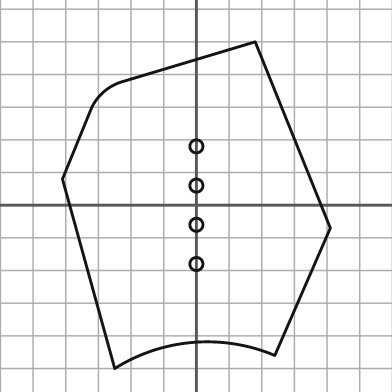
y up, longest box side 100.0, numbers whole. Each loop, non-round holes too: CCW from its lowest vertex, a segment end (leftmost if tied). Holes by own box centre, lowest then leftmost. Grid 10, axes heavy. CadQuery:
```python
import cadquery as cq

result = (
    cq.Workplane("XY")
    .moveTo(-25.0, -50.0)
    .threePointArc((-1.0, -42.0), (24.0, -46.0))
    .lineTo(41.0, -7.0)
    .lineTo(18.0, 50.0)
    .lineTo(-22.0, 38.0)
    .threePointArc((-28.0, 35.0), (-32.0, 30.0))
    .lineTo(-41.0, 8.0)
    .close()
    .moveTo(0.0, -18.0)
    .circle(2.0)
    .moveTo(0.0, -6.0)
    .circle(2.0)
    .moveTo(0.0, 6.0)
    .circle(2.0)
    .moveTo(0.0, 18.0)
    .circle(2.0)
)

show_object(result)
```